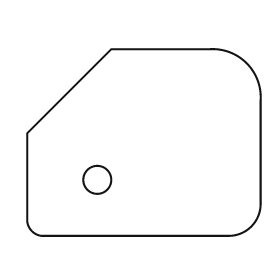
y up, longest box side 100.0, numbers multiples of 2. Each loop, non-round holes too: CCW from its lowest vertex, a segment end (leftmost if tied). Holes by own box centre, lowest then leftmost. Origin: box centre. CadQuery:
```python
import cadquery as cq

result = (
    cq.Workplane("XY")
    .moveTo(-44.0, -40.0)
    .lineTo(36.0, -40.0)
    .threePointArc((46.0, -36.0), (50.0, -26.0))
    .lineTo(50.0, 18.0)
    .threePointArc((44.0, 34.0), (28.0, 40.0))
    .lineTo(-14.0, 40.0)
    .lineTo(-50.0, 4.0)
    .lineTo(-50.0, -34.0)
    .threePointArc((-48.0, -38.0), (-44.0, -40.0))
    .close()
    .moveTo(-20.0, -16.0)
    .circle(6.0)
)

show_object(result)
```